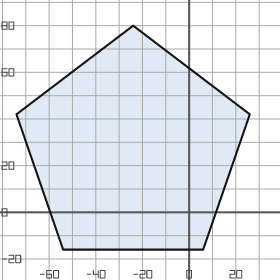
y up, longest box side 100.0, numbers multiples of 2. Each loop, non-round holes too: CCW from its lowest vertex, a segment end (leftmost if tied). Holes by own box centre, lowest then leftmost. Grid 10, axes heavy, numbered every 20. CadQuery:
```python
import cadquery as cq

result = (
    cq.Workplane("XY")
    .moveTo(-54.0, -16.0)
    .lineTo(6.0, -16.0)
    .lineTo(26.0, 42.0)
    .lineTo(-24.0, 80.0)
    .lineTo(-74.0, 42.0)
    .close()
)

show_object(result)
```